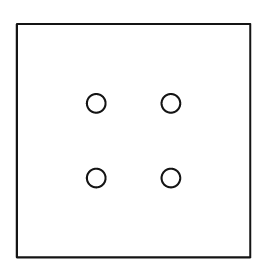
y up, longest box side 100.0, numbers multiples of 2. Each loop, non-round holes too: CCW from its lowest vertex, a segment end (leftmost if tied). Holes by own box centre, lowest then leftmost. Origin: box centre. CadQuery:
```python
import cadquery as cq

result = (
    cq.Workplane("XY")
    .moveTo(-50.0, -50.0)
    .lineTo(50.0, -50.0)
    .lineTo(50.0, 50.0)
    .lineTo(-50.0, 50.0)
    .close()
    .moveTo(-16.0, -16.0)
    .circle(4.0)
    .moveTo(16.0, -16.0)
    .circle(4.0)
    .moveTo(-16.0, 16.0)
    .circle(4.0)
    .moveTo(16.0, 16.0)
    .circle(4.0)
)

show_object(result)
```